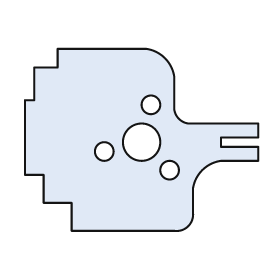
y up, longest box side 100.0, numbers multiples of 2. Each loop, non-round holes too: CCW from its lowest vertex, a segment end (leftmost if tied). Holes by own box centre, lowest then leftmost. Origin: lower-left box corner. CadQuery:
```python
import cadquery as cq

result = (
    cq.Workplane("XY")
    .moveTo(20.0, 0.0)
    .lineTo(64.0, 0.0)
    .threePointArc((70.0, 2.0), (72.0, 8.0))
    .lineTo(72.0, 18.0)
    .threePointArc((76.0, 26.0), (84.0, 30.0))
    .lineTo(100.0, 30.0)
    .lineTo(100.0, 36.0)
    .lineTo(84.0, 36.0)
    .lineTo(84.0, 40.0)
    .lineTo(100.0, 40.0)
    .lineTo(100.0, 46.0)
    .lineTo(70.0, 46.0)
    .threePointArc((66.0, 48.0), (64.0, 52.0))
    .lineTo(64.0, 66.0)
    .threePointArc((60.0, 74.0), (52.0, 78.0))
    .lineTo(14.0, 78.0)
    .lineTo(14.0, 70.0)
    .lineTo(4.0, 70.0)
    .lineTo(4.0, 56.0)
    .lineTo(0.0, 56.0)
    .lineTo(0.0, 24.0)
    .lineTo(8.0, 24.0)
    .lineTo(8.0, 12.0)
    .lineTo(20.0, 12.0)
    .close()
    .moveTo(62.0, 26.0)
    .circle(4.0)
    .moveTo(34.0, 34.0)
    .circle(4.0)
    .moveTo(50.0, 38.0)
    .circle(8.0)
    .moveTo(54.0, 54.0)
    .circle(4.0)
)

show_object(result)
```